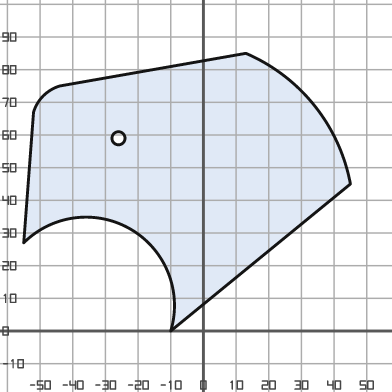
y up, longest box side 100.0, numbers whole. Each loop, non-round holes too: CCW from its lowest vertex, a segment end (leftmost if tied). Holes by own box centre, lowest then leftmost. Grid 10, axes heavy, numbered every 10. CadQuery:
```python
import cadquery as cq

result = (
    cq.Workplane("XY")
    .moveTo(-10.0, 0.0)
    .lineTo(45.0, 45.0)
    .threePointArc((34.0, 69.0), (13.0, 85.0))
    .lineTo(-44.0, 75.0)
    .threePointArc((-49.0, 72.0), (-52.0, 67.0))
    .lineTo(-55.0, 27.0)
    .threePointArc((-22.0, 31.0), (-10.0, 0.0))
    .close()
    .moveTo(-26.0, 59.0)
    .circle(2.0)
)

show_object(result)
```